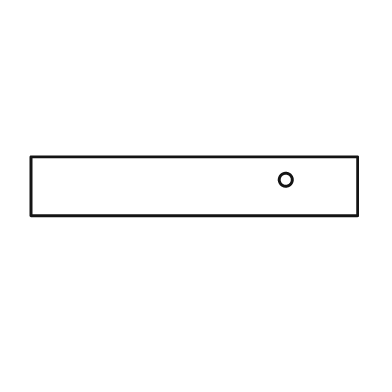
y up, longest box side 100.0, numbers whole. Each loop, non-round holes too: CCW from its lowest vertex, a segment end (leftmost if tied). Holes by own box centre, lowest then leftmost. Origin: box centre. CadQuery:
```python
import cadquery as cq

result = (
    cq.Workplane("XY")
    .moveTo(-50.0, -9.0)
    .lineTo(50.0, -9.0)
    .lineTo(50.0, 9.0)
    .lineTo(-50.0, 9.0)
    .close()
    .moveTo(28.0, 2.0)
    .circle(2.0)
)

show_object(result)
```